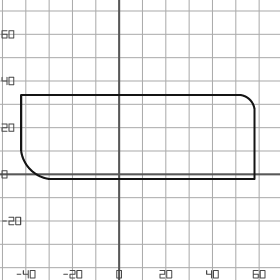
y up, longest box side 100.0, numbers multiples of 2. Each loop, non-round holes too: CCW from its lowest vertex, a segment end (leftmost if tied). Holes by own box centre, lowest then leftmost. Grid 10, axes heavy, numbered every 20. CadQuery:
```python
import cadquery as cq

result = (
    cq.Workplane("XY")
    .moveTo(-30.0, -2.0)
    .lineTo(58.0, -2.0)
    .lineTo(58.0, 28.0)
    .threePointArc((56.0, 32.0), (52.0, 34.0))
    .lineTo(-42.0, 34.0)
    .lineTo(-42.0, 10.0)
    .threePointArc((-38.0, 2.0), (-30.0, -2.0))
    .close()
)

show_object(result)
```